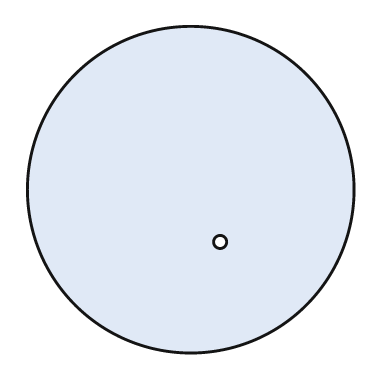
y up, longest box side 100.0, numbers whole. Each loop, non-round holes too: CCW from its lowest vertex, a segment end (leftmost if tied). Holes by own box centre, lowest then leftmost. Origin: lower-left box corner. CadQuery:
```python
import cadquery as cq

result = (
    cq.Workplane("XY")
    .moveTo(50.0, 50.0)
    .circle(50.0)
    .moveTo(59.0, 34.0)
    .circle(2.0)
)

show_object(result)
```